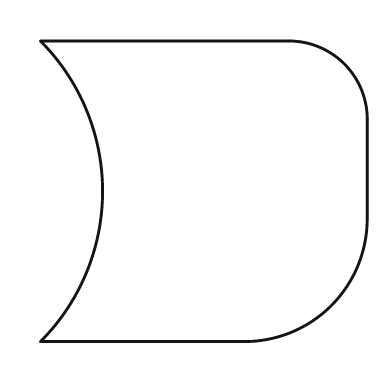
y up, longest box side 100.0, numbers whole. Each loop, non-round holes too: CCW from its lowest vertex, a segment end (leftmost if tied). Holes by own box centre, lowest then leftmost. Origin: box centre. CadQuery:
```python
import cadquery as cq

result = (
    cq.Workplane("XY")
    .moveTo(-50.0, -46.0)
    .lineTo(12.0, -46.0)
    .threePointArc((39.0, -35.0), (50.0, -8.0))
    .lineTo(50.0, 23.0)
    .threePointArc((43.0, 39.0), (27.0, 46.0))
    .lineTo(-50.0, 46.0)
    .threePointArc((-31.0, 0.0), (-50.0, -46.0))
    .close()
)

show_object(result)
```